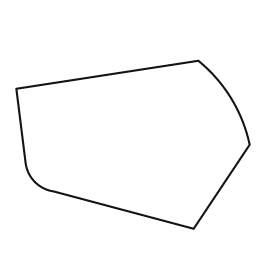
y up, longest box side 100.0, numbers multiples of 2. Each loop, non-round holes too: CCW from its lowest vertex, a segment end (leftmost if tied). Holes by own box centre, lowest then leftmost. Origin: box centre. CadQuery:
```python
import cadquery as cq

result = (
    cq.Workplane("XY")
    .moveTo(26.0, -36.0)
    .lineTo(50.0, 0.0)
    .threePointArc((42.0, 20.0), (28.0, 36.0))
    .lineTo(-50.0, 24.0)
    .lineTo(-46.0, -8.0)
    .threePointArc((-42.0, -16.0), (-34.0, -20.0))
    .close()
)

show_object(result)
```